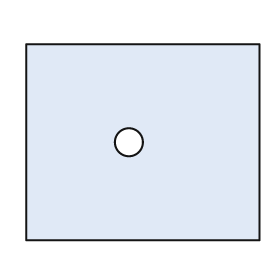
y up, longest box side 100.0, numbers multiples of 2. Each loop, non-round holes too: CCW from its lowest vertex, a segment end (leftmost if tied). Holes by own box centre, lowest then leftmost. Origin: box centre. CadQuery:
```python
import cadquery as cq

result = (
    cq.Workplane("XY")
    .moveTo(-50.0, -42.0)
    .lineTo(50.0, -42.0)
    .lineTo(50.0, 42.0)
    .lineTo(-50.0, 42.0)
    .close()
    .moveTo(-6.0, 0.0)
    .circle(6.0)
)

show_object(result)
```